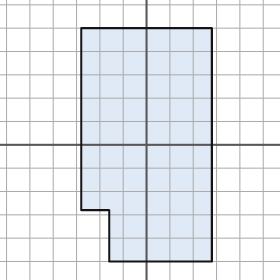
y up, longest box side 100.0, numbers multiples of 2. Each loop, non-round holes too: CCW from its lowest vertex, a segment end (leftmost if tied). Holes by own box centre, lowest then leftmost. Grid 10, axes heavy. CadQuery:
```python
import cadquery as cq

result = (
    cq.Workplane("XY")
    .moveTo(-16.0, -50.0)
    .lineTo(28.0, -50.0)
    .lineTo(28.0, 50.0)
    .lineTo(-28.0, 50.0)
    .lineTo(-28.0, -28.0)
    .lineTo(-16.0, -28.0)
    .close()
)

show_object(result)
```